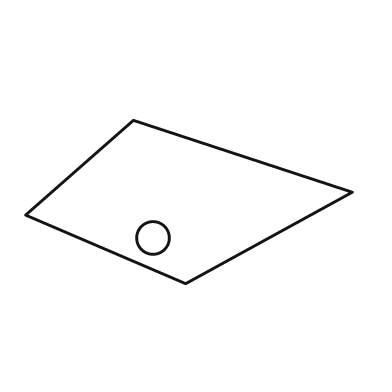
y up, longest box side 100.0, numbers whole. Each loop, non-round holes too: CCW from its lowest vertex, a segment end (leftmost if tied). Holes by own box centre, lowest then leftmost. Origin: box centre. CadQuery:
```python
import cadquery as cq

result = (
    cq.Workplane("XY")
    .moveTo(-1.0, -25.0)
    .lineTo(50.0, 3.0)
    .lineTo(-17.0, 25.0)
    .lineTo(-50.0, -4.0)
    .close()
    .moveTo(-11.0, -11.0)
    .circle(5.0)
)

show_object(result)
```